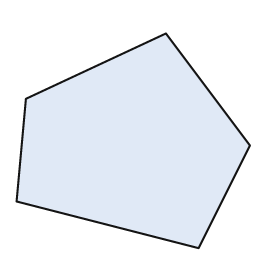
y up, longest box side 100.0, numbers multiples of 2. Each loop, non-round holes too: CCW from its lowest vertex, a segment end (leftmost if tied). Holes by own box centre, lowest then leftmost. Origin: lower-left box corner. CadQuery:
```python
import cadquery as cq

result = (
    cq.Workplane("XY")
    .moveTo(78.0, 0.0)
    .lineTo(100.0, 44.0)
    .lineTo(64.0, 92.0)
    .lineTo(4.0, 64.0)
    .lineTo(0.0, 20.0)
    .close()
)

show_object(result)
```